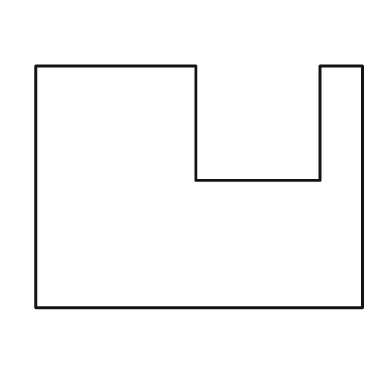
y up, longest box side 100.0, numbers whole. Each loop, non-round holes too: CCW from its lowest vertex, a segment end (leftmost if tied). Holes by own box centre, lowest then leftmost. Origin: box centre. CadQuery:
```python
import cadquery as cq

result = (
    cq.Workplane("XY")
    .moveTo(-50.0, -37.0)
    .lineTo(50.0, -37.0)
    .lineTo(50.0, 37.0)
    .lineTo(37.0, 37.0)
    .lineTo(37.0, 2.0)
    .lineTo(-1.0, 2.0)
    .lineTo(-1.0, 37.0)
    .lineTo(-50.0, 37.0)
    .close()
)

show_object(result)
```